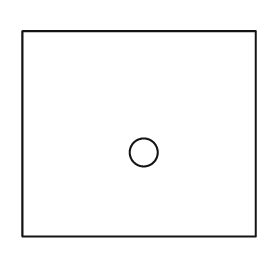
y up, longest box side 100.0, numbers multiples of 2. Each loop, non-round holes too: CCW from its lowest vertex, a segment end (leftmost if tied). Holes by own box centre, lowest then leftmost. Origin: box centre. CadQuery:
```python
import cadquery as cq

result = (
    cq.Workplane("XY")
    .moveTo(-50.0, -44.0)
    .lineTo(50.0, -44.0)
    .lineTo(50.0, 44.0)
    .lineTo(-50.0, 44.0)
    .close()
    .moveTo(2.0, -8.0)
    .circle(6.0)
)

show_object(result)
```